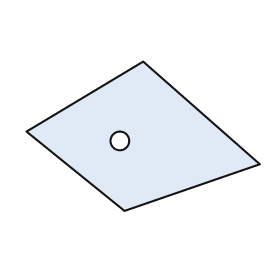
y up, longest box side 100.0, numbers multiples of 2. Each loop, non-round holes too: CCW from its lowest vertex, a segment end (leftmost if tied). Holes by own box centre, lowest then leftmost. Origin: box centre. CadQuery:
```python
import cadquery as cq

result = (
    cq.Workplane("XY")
    .moveTo(-8.0, -32.0)
    .lineTo(50.0, -12.0)
    .lineTo(0.0, 32.0)
    .lineTo(-50.0, 2.0)
    .close()
    .moveTo(-10.0, -2.0)
    .circle(4.0)
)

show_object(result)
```